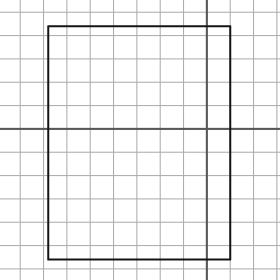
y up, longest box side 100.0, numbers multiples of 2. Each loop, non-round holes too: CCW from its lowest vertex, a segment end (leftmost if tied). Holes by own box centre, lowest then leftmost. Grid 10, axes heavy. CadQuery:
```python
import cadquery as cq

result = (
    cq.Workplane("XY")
    .moveTo(-68.0, -56.0)
    .lineTo(10.0, -56.0)
    .lineTo(10.0, 44.0)
    .lineTo(-68.0, 44.0)
    .close()
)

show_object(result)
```